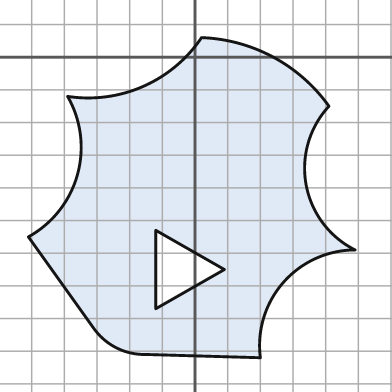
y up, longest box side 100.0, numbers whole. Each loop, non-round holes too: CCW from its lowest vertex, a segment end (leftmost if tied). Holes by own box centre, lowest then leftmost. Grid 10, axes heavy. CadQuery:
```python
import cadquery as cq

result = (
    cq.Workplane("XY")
    .moveTo(20.0, -92.0)
    .threePointArc((27.0, -69.0), (49.0, -59.0))
    .threePointArc((34.0, -39.0), (41.0, -15.0))
    .threePointArc((24.0, 0.0), (2.0, 6.0))
    .threePointArc((-16.0, -9.0), (-39.0, -12.0))
    .threePointArc((-36.0, -36.0), (-51.0, -55.0))
    .lineTo(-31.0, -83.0)
    .threePointArc((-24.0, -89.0), (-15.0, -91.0))
    .close()
    .moveTo(-12.0, -77.0)
    .lineTo(9.0, -65.0)
    .lineTo(-12.0, -53.0)
    .close()
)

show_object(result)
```